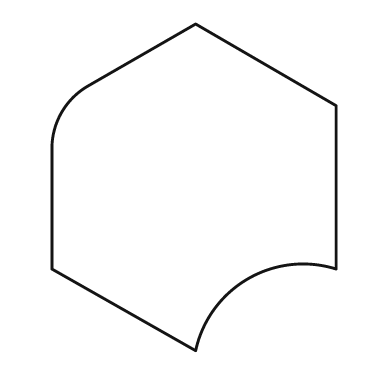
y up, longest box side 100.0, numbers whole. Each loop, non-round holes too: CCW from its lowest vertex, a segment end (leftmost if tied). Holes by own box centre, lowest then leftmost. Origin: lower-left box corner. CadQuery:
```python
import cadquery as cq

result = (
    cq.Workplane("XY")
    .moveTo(44.0, 0.0)
    .threePointArc((60.0, 22.0), (87.0, 25.0))
    .lineTo(87.0, 75.0)
    .lineTo(44.0, 100.0)
    .lineTo(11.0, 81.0)
    .threePointArc((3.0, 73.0), (0.0, 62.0))
    .lineTo(0.0, 25.0)
    .close()
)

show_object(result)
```